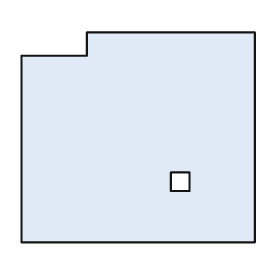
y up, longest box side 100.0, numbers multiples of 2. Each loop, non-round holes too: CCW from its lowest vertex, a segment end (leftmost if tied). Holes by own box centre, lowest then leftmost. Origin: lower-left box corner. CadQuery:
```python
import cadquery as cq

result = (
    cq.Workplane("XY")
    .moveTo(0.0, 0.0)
    .lineTo(100.0, 0.0)
    .lineTo(100.0, 90.0)
    .lineTo(28.0, 90.0)
    .lineTo(28.0, 80.0)
    .lineTo(0.0, 80.0)
    .close()
    .moveTo(64.0, 22.0)
    .lineTo(72.0, 22.0)
    .lineTo(72.0, 30.0)
    .lineTo(64.0, 30.0)
    .close()
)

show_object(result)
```